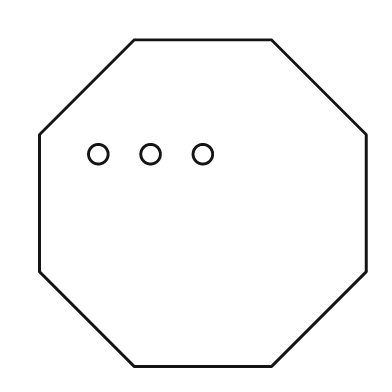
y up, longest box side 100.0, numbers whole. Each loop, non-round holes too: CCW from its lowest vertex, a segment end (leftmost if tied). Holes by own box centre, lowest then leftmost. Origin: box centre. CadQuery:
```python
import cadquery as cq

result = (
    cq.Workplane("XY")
    .moveTo(-21.0, -50.0)
    .lineTo(21.0, -50.0)
    .lineTo(50.0, -21.0)
    .lineTo(50.0, 21.0)
    .lineTo(21.0, 50.0)
    .lineTo(-21.0, 50.0)
    .lineTo(-50.0, 21.0)
    .lineTo(-50.0, -21.0)
    .close()
    .moveTo(-32.0, 15.0)
    .circle(3.0)
    .moveTo(-16.0, 15.0)
    .circle(3.0)
    .moveTo(0.0, 15.0)
    .circle(3.0)
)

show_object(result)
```